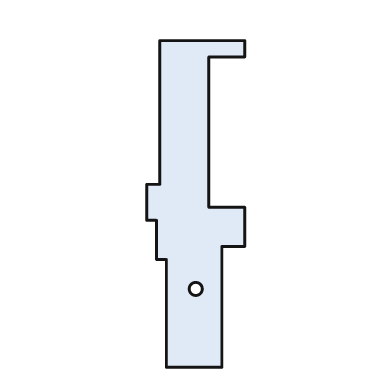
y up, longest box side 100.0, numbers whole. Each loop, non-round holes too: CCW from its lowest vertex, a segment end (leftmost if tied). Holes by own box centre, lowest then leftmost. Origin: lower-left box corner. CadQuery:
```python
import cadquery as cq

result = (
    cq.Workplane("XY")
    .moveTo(6.0, 0.0)
    .lineTo(23.0, 0.0)
    .lineTo(23.0, 37.0)
    .lineTo(30.0, 37.0)
    .lineTo(30.0, 49.0)
    .lineTo(19.0, 49.0)
    .lineTo(19.0, 95.0)
    .lineTo(30.0, 95.0)
    .lineTo(30.0, 100.0)
    .lineTo(4.0, 100.0)
    .lineTo(4.0, 56.0)
    .lineTo(0.0, 56.0)
    .lineTo(0.0, 45.0)
    .lineTo(3.0, 45.0)
    .lineTo(3.0, 33.0)
    .lineTo(6.0, 33.0)
    .close()
    .moveTo(15.0, 24.0)
    .circle(2.0)
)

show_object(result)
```